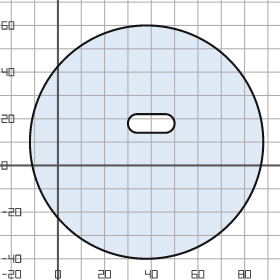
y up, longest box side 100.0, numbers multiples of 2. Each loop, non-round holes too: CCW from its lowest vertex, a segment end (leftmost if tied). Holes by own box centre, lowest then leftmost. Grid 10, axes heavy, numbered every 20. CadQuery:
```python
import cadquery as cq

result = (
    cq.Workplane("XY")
    .moveTo(38.0, 10.0)
    .circle(50.0)
    .moveTo(34.0, 14.0)
    .lineTo(46.0, 14.0)
    .threePointArc((50.0, 18.0), (46.0, 22.0))
    .lineTo(34.0, 22.0)
    .threePointArc((30.0, 18.0), (34.0, 14.0))
    .close()
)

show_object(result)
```